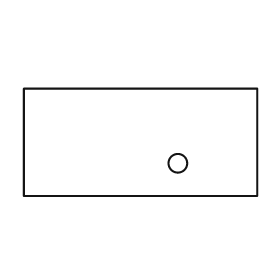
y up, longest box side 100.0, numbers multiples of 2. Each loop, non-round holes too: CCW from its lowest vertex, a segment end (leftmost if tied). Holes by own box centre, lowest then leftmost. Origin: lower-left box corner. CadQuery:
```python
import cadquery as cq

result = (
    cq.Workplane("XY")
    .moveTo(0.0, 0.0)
    .lineTo(100.0, 0.0)
    .lineTo(100.0, 46.0)
    .lineTo(0.0, 46.0)
    .close()
    .moveTo(66.0, 14.0)
    .circle(4.0)
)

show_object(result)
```